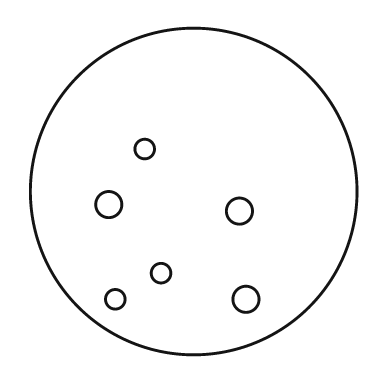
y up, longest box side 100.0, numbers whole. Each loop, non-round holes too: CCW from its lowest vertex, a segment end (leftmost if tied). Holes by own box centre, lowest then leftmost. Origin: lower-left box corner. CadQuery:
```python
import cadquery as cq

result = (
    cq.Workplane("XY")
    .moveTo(50.0, 50.0)
    .circle(50.0)
    .moveTo(26.0, 17.0)
    .circle(3.0)
    .moveTo(66.0, 17.0)
    .circle(4.0)
    .moveTo(40.0, 25.0)
    .circle(3.0)
    .moveTo(64.0, 44.0)
    .circle(4.0)
    .moveTo(24.0, 46.0)
    .circle(4.0)
    .moveTo(35.0, 63.0)
    .circle(3.0)
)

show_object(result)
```